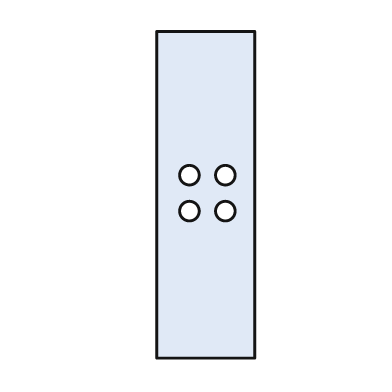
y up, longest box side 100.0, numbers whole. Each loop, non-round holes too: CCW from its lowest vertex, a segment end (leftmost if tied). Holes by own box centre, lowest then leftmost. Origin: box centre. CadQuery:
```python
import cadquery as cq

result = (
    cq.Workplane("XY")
    .moveTo(-15.0, -50.0)
    .lineTo(15.0, -50.0)
    .lineTo(15.0, 50.0)
    .lineTo(-15.0, 50.0)
    .close()
    .moveTo(-5.0, -5.0)
    .circle(3.0)
    .moveTo(6.0, -5.0)
    .circle(3.0)
    .moveTo(-5.0, 6.0)
    .circle(3.0)
    .moveTo(6.0, 6.0)
    .circle(3.0)
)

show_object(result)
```